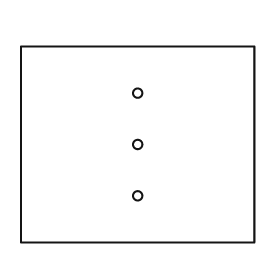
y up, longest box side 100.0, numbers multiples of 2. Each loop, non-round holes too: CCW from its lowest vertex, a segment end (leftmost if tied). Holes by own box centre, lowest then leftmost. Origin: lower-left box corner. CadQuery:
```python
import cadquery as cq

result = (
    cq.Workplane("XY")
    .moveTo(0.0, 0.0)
    .lineTo(100.0, 0.0)
    .lineTo(100.0, 84.0)
    .lineTo(0.0, 84.0)
    .close()
    .moveTo(50.0, 20.0)
    .circle(2.0)
    .moveTo(50.0, 42.0)
    .circle(2.0)
    .moveTo(50.0, 64.0)
    .circle(2.0)
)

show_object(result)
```